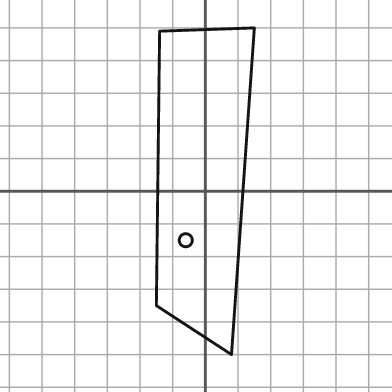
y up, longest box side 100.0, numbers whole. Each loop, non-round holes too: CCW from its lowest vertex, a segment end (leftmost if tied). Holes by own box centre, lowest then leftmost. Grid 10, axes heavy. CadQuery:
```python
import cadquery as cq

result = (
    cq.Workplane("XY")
    .moveTo(8.0, -50.0)
    .lineTo(15.0, 50.0)
    .lineTo(-14.0, 49.0)
    .lineTo(-15.0, -35.0)
    .close()
    .moveTo(-6.0, -15.0)
    .circle(2.0)
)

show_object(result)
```